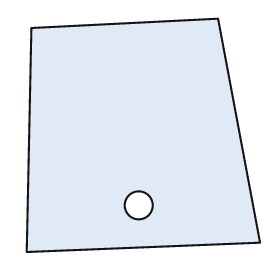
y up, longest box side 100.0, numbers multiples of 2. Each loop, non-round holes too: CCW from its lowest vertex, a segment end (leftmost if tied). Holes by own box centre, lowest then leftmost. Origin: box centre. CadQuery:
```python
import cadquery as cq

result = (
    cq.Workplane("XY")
    .moveTo(-50.0, -50.0)
    .lineTo(50.0, -46.0)
    .lineTo(32.0, 50.0)
    .lineTo(-48.0, 46.0)
    .close()
    .moveTo(-2.0, -30.0)
    .circle(6.0)
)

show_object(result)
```